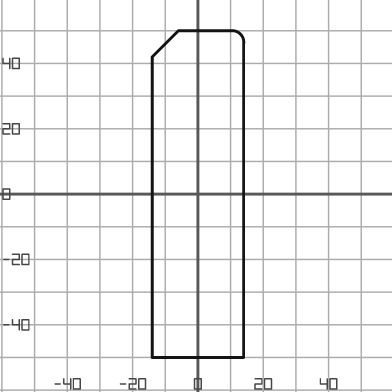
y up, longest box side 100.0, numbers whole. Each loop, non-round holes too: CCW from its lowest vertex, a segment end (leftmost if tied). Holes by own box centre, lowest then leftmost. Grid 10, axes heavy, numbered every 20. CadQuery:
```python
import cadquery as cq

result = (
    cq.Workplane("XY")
    .moveTo(-14.0, -50.0)
    .lineTo(14.0, -50.0)
    .lineTo(14.0, 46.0)
    .threePointArc((13.0, 49.0), (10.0, 50.0))
    .lineTo(-6.0, 50.0)
    .lineTo(-14.0, 42.0)
    .close()
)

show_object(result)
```